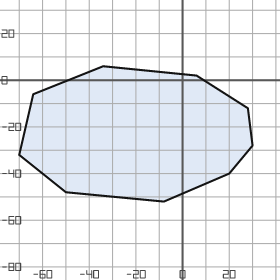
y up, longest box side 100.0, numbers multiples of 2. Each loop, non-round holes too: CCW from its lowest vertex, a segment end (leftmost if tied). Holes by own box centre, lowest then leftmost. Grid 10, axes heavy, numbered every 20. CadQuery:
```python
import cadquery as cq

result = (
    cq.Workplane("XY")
    .moveTo(-8.0, -52.0)
    .lineTo(20.0, -40.0)
    .lineTo(30.0, -28.0)
    .lineTo(28.0, -12.0)
    .lineTo(6.0, 2.0)
    .lineTo(-34.0, 6.0)
    .lineTo(-64.0, -6.0)
    .lineTo(-70.0, -32.0)
    .lineTo(-50.0, -48.0)
    .close()
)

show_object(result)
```